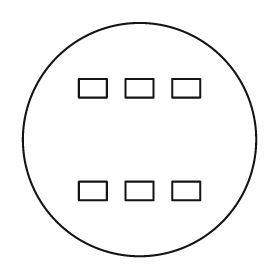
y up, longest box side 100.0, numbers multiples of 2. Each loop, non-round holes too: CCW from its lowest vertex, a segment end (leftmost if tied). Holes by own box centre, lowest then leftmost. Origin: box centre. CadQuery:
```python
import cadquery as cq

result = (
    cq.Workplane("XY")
    .moveTo(0.0, 0.0)
    .circle(50.0)
    .moveTo(-26.0, -26.0)
    .lineTo(-14.0, -26.0)
    .lineTo(-14.0, -18.0)
    .lineTo(-26.0, -18.0)
    .close()
    .moveTo(-6.0, -26.0)
    .lineTo(6.0, -26.0)
    .lineTo(6.0, -18.0)
    .lineTo(-6.0, -18.0)
    .close()
    .moveTo(14.0, -26.0)
    .lineTo(26.0, -26.0)
    .lineTo(26.0, -18.0)
    .lineTo(14.0, -18.0)
    .close()
    .moveTo(-26.0, 18.0)
    .lineTo(-14.0, 18.0)
    .lineTo(-14.0, 26.0)
    .lineTo(-26.0, 26.0)
    .close()
    .moveTo(-6.0, 18.0)
    .lineTo(6.0, 18.0)
    .lineTo(6.0, 26.0)
    .lineTo(-6.0, 26.0)
    .close()
    .moveTo(14.0, 18.0)
    .lineTo(26.0, 18.0)
    .lineTo(26.0, 26.0)
    .lineTo(14.0, 26.0)
    .close()
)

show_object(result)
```